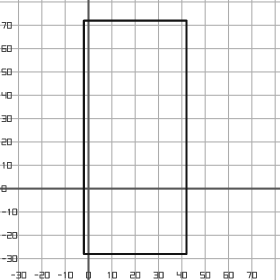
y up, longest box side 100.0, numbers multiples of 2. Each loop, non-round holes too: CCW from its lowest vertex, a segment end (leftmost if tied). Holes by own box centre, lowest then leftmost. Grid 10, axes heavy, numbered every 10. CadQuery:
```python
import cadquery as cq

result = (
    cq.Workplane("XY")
    .moveTo(-2.0, -28.0)
    .lineTo(42.0, -28.0)
    .lineTo(42.0, 72.0)
    .lineTo(-2.0, 72.0)
    .close()
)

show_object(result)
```